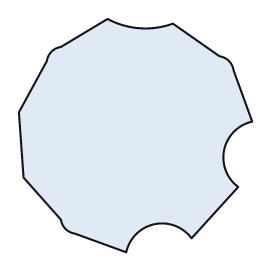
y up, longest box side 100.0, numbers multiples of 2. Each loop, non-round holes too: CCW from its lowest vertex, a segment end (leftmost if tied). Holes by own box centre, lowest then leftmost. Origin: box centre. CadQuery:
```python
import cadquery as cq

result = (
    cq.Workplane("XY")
    .moveTo(-4.0, -50.0)
    .threePointArc((8.0, -38.0), (24.0, -44.0))
    .lineTo(44.0, -22.0)
    .threePointArc((38.0, -6.0), (50.0, 6.0))
    .lineTo(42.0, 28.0)
    .threePointArc((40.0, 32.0), (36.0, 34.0))
    .lineTo(16.0, 48.0)
    .threePointArc((2.0, 46.0), (-12.0, 50.0))
    .lineTo(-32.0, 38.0)
    .threePointArc((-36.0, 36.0), (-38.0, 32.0))
    .lineTo(-50.0, 10.0)
    .lineTo(-48.0, -18.0)
    .lineTo(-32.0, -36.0)
    .threePointArc((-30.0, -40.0), (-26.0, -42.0))
    .close()
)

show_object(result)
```